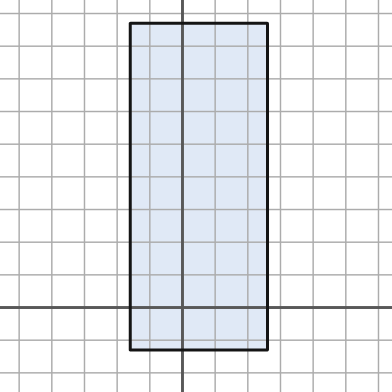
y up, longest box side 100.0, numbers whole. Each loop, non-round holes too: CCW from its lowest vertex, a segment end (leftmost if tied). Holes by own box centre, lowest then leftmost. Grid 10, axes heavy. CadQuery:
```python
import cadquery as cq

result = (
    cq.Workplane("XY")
    .moveTo(-16.0, -13.0)
    .lineTo(26.0, -13.0)
    .lineTo(26.0, 87.0)
    .lineTo(-16.0, 87.0)
    .close()
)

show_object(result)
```